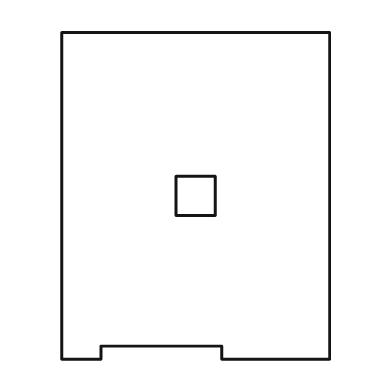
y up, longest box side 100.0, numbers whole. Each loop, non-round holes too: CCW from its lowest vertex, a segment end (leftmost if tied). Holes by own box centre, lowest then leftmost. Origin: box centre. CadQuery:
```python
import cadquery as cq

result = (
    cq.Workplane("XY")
    .moveTo(-41.0, -50.0)
    .lineTo(-29.0, -50.0)
    .lineTo(-29.0, -46.0)
    .lineTo(8.0, -46.0)
    .lineTo(8.0, -50.0)
    .lineTo(41.0, -50.0)
    .lineTo(41.0, 50.0)
    .lineTo(-41.0, 50.0)
    .close()
    .moveTo(-6.0, -6.0)
    .lineTo(6.0, -6.0)
    .lineTo(6.0, 6.0)
    .lineTo(-6.0, 6.0)
    .close()
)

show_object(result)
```